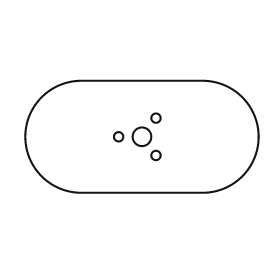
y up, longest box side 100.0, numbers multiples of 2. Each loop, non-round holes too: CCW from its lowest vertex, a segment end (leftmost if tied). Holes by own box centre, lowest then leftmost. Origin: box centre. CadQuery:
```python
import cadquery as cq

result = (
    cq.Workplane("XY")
    .moveTo(-26.0, -24.0)
    .lineTo(26.0, -24.0)
    .threePointArc((50.0, 0.0), (26.0, 24.0))
    .lineTo(-26.0, 24.0)
    .threePointArc((-50.0, 0.0), (-26.0, -24.0))
    .close()
    .moveTo(6.0, -8.0)
    .circle(2.0)
    .moveTo(-10.0, 0.0)
    .circle(2.0)
    .moveTo(0.0, 0.0)
    .circle(4.0)
    .moveTo(6.0, 8.0)
    .circle(2.0)
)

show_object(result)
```